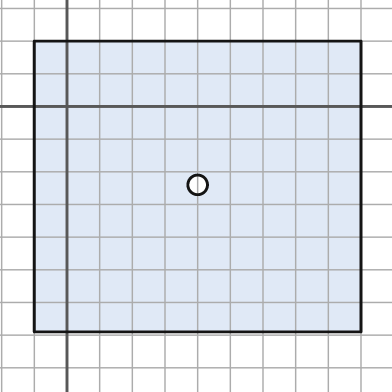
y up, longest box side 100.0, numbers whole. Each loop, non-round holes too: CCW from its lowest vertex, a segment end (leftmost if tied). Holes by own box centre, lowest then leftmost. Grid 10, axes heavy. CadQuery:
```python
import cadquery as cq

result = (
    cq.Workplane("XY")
    .moveTo(-10.0, -69.0)
    .lineTo(90.0, -69.0)
    .lineTo(90.0, 20.0)
    .lineTo(-10.0, 20.0)
    .close()
    .moveTo(40.0, -24.0)
    .circle(3.0)
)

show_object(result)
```